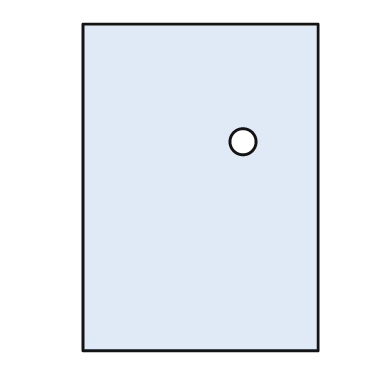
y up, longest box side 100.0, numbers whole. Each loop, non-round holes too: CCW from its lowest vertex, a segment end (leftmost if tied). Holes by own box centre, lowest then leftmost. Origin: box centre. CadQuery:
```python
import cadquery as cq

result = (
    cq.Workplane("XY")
    .moveTo(-36.0, -50.0)
    .lineTo(36.0, -50.0)
    .lineTo(36.0, 50.0)
    .lineTo(-36.0, 50.0)
    .close()
    .moveTo(13.0, 14.0)
    .circle(4.0)
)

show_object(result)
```